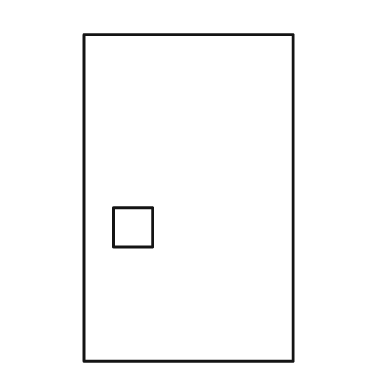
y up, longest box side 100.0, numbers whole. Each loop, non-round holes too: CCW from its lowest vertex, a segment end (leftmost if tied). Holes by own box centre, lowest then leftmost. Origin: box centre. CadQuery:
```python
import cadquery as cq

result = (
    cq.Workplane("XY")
    .moveTo(-32.0, -50.0)
    .lineTo(32.0, -50.0)
    .lineTo(32.0, 50.0)
    .lineTo(-32.0, 50.0)
    .close()
    .moveTo(-23.0, -15.0)
    .lineTo(-11.0, -15.0)
    .lineTo(-11.0, -3.0)
    .lineTo(-23.0, -3.0)
    .close()
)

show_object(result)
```